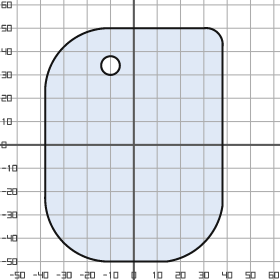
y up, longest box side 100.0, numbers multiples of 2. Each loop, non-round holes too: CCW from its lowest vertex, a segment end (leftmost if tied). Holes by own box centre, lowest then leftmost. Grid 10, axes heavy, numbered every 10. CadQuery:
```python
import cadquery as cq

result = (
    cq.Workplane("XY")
    .moveTo(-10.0, -50.0)
    .lineTo(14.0, -50.0)
    .threePointArc((30.0, -42.0), (38.0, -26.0))
    .lineTo(38.0, 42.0)
    .threePointArc((36.0, 48.0), (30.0, 50.0))
    .lineTo(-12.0, 50.0)
    .threePointArc((-30.0, 42.0), (-38.0, 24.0))
    .lineTo(-38.0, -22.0)
    .threePointArc((-30.0, -42.0), (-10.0, -50.0))
    .close()
    .moveTo(-10.0, 34.0)
    .circle(4.0)
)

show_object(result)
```